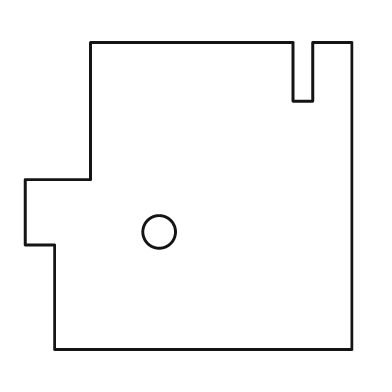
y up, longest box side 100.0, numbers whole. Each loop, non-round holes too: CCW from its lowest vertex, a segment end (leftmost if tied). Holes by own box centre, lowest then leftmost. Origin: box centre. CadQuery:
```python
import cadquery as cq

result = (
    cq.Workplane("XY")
    .moveTo(-41.0, -47.0)
    .lineTo(50.0, -47.0)
    .lineTo(50.0, 47.0)
    .lineTo(38.0, 47.0)
    .lineTo(38.0, 29.0)
    .lineTo(32.0, 29.0)
    .lineTo(32.0, 47.0)
    .lineTo(-30.0, 47.0)
    .lineTo(-30.0, 5.0)
    .lineTo(-50.0, 5.0)
    .lineTo(-50.0, -15.0)
    .lineTo(-41.0, -15.0)
    .close()
    .moveTo(-9.0, -11.0)
    .circle(5.0)
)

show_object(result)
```